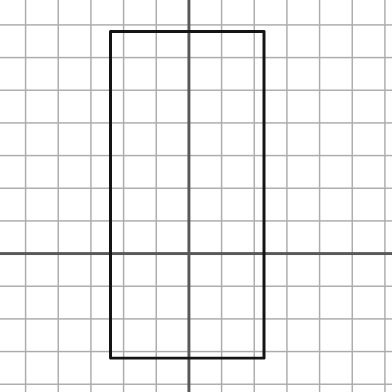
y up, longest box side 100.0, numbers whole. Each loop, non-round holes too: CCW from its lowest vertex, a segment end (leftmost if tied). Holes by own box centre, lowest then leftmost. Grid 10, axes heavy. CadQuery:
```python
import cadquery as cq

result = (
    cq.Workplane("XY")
    .moveTo(-24.0, -32.0)
    .lineTo(23.0, -32.0)
    .lineTo(23.0, 68.0)
    .lineTo(-24.0, 68.0)
    .close()
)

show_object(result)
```